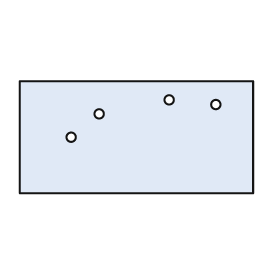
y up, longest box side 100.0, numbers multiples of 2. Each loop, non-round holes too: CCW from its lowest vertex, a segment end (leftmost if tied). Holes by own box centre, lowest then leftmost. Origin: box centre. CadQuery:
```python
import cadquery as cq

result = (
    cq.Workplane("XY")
    .moveTo(-50.0, -24.0)
    .lineTo(50.0, -24.0)
    .lineTo(50.0, 24.0)
    .lineTo(-50.0, 24.0)
    .close()
    .moveTo(-28.0, 0.0)
    .circle(2.0)
    .moveTo(-16.0, 10.0)
    .circle(2.0)
    .moveTo(34.0, 14.0)
    .circle(2.0)
    .moveTo(14.0, 16.0)
    .circle(2.0)
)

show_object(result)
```